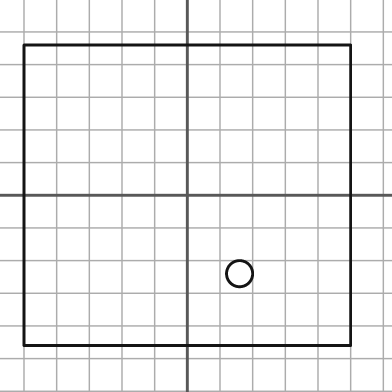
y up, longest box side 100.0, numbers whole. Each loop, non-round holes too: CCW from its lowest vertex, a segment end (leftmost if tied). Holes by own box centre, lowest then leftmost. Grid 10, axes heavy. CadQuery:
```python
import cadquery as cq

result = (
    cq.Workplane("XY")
    .moveTo(-50.0, -46.0)
    .lineTo(50.0, -46.0)
    .lineTo(50.0, 46.0)
    .lineTo(-50.0, 46.0)
    .close()
    .moveTo(16.0, -24.0)
    .circle(4.0)
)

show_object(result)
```